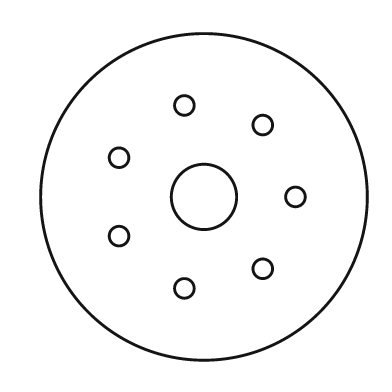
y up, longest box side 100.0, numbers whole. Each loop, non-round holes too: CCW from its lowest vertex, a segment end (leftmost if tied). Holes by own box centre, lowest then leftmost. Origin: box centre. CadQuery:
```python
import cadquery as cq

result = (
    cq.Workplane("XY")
    .moveTo(0.0, 0.0)
    .circle(50.0)
    .moveTo(-6.0, -28.0)
    .circle(3.0)
    .moveTo(18.0, -22.0)
    .circle(3.0)
    .moveTo(-26.0, -12.0)
    .circle(3.0)
    .moveTo(0.0, 0.0)
    .circle(10.0)
    .moveTo(28.0, 0.0)
    .circle(3.0)
    .moveTo(-26.0, 12.0)
    .circle(3.0)
    .moveTo(18.0, 22.0)
    .circle(3.0)
    .moveTo(-6.0, 28.0)
    .circle(3.0)
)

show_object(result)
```